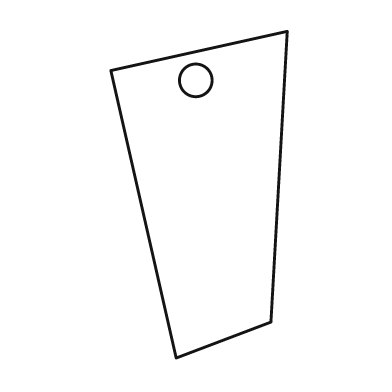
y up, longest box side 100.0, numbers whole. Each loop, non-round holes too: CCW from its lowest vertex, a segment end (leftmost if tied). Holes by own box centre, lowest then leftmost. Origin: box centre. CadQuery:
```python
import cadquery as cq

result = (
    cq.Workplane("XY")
    .moveTo(-7.0, -50.0)
    .lineTo(22.0, -39.0)
    .lineTo(27.0, 50.0)
    .lineTo(-27.0, 38.0)
    .close()
    .moveTo(-1.0, 35.0)
    .circle(5.0)
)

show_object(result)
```